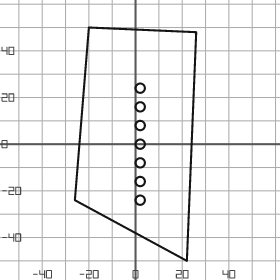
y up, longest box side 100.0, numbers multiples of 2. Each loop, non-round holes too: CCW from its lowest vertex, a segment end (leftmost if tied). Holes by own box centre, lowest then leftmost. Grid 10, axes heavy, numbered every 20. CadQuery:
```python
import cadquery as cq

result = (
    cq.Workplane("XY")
    .moveTo(22.0, -50.0)
    .lineTo(26.0, 48.0)
    .lineTo(-20.0, 50.0)
    .lineTo(-26.0, -24.0)
    .close()
    .moveTo(2.0, -24.0)
    .circle(2.0)
    .moveTo(2.0, -16.0)
    .circle(2.0)
    .moveTo(2.0, -8.0)
    .circle(2.0)
    .moveTo(2.0, 0.0)
    .circle(2.0)
    .moveTo(2.0, 8.0)
    .circle(2.0)
    .moveTo(2.0, 16.0)
    .circle(2.0)
    .moveTo(2.0, 24.0)
    .circle(2.0)
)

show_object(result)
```